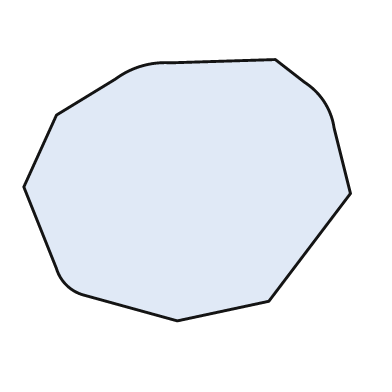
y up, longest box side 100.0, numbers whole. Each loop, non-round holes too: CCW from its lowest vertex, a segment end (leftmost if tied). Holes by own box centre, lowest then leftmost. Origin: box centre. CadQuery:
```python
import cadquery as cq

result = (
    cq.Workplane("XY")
    .moveTo(-3.0, -40.0)
    .lineTo(25.0, -34.0)
    .lineTo(50.0, -1.0)
    .lineTo(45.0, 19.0)
    .threePointArc((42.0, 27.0), (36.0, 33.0))
    .lineTo(27.0, 40.0)
    .lineTo(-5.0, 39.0)
    .threePointArc((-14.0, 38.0), (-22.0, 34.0))
    .lineTo(-40.0, 23.0)
    .lineTo(-50.0, 1.0)
    .lineTo(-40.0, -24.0)
    .threePointArc((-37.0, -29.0), (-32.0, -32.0))
    .close()
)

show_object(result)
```